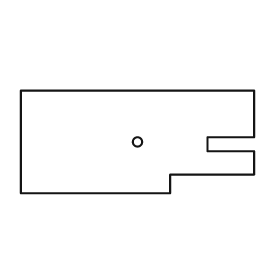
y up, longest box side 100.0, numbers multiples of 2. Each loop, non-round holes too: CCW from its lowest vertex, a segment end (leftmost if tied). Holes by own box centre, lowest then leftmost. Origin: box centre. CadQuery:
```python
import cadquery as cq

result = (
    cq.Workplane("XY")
    .moveTo(-50.0, -22.0)
    .lineTo(14.0, -22.0)
    .lineTo(14.0, -14.0)
    .lineTo(50.0, -14.0)
    .lineTo(50.0, -4.0)
    .lineTo(30.0, -4.0)
    .lineTo(30.0, 2.0)
    .lineTo(50.0, 2.0)
    .lineTo(50.0, 22.0)
    .lineTo(-50.0, 22.0)
    .close()
    .moveTo(0.0, 0.0)
    .circle(2.0)
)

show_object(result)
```